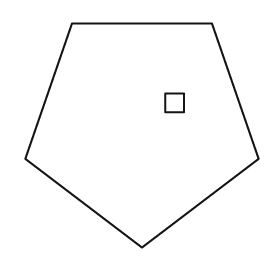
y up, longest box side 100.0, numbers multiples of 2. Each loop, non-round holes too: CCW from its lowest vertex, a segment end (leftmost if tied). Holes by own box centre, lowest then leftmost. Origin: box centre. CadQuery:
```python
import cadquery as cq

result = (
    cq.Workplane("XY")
    .moveTo(0.0, -48.0)
    .lineTo(50.0, -10.0)
    .lineTo(30.0, 48.0)
    .lineTo(-30.0, 48.0)
    .lineTo(-50.0, -10.0)
    .close()
    .moveTo(10.0, 10.0)
    .lineTo(18.0, 10.0)
    .lineTo(18.0, 18.0)
    .lineTo(10.0, 18.0)
    .close()
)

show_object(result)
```